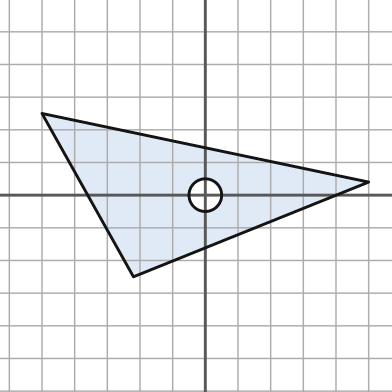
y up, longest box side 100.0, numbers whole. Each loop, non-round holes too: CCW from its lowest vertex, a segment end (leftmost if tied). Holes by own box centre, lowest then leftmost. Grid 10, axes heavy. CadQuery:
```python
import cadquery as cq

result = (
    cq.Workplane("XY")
    .moveTo(-22.0, -25.0)
    .lineTo(50.0, 4.0)
    .lineTo(-50.0, 25.0)
    .close()
    .moveTo(0.0, 0.0)
    .circle(5.0)
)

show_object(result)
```